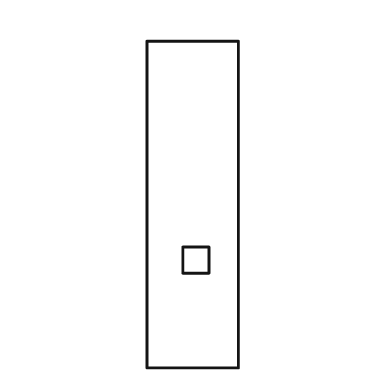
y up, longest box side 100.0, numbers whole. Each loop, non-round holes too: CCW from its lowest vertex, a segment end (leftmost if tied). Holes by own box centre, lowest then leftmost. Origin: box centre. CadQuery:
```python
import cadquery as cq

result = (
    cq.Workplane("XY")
    .moveTo(-14.0, -50.0)
    .lineTo(14.0, -50.0)
    .lineTo(14.0, 50.0)
    .lineTo(-14.0, 50.0)
    .close()
    .moveTo(-3.0, -21.0)
    .lineTo(5.0, -21.0)
    .lineTo(5.0, -13.0)
    .lineTo(-3.0, -13.0)
    .close()
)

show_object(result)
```